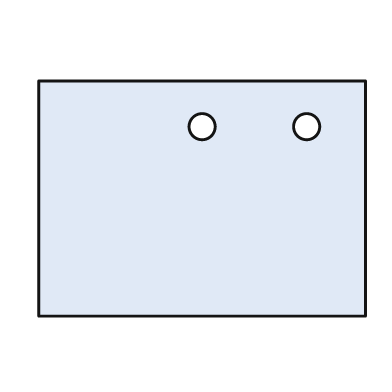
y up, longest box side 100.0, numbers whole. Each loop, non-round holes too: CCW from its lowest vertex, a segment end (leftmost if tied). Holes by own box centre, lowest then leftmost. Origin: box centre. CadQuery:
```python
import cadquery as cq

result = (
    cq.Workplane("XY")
    .moveTo(-50.0, -36.0)
    .lineTo(50.0, -36.0)
    .lineTo(50.0, 36.0)
    .lineTo(-50.0, 36.0)
    .close()
    .moveTo(0.0, 22.0)
    .circle(4.0)
    .moveTo(32.0, 22.0)
    .circle(4.0)
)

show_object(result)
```